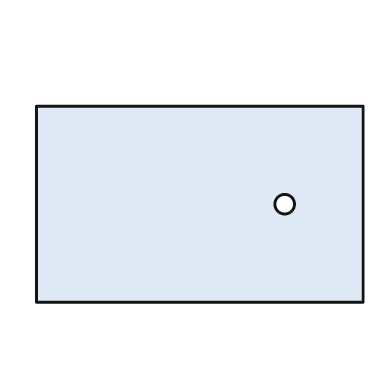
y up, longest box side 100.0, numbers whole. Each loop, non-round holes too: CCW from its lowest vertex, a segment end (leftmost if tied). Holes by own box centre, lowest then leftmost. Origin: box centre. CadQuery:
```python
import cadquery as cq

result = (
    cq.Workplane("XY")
    .moveTo(-50.0, -30.0)
    .lineTo(50.0, -30.0)
    .lineTo(50.0, 30.0)
    .lineTo(-50.0, 30.0)
    .close()
    .moveTo(26.0, 0.0)
    .circle(3.0)
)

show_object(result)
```